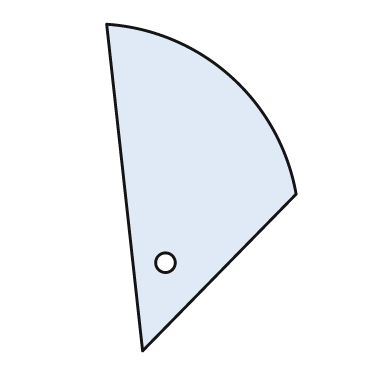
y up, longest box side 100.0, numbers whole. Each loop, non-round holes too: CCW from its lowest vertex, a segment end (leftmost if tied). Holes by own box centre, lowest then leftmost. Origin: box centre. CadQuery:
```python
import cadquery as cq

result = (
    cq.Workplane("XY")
    .moveTo(-18.0, -50.0)
    .lineTo(29.0, -2.0)
    .threePointArc((9.0, 34.0), (-29.0, 50.0))
    .close()
    .moveTo(-11.0, -23.0)
    .circle(3.0)
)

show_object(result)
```